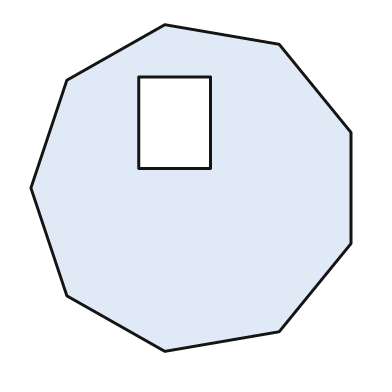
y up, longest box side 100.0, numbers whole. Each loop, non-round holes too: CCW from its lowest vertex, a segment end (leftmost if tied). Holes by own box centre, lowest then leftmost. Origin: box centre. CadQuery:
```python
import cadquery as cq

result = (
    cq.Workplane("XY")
    .moveTo(-8.0, -50.0)
    .lineTo(27.0, -44.0)
    .lineTo(49.0, -17.0)
    .lineTo(49.0, 17.0)
    .lineTo(27.0, 44.0)
    .lineTo(-8.0, 50.0)
    .lineTo(-38.0, 33.0)
    .lineTo(-49.0, 0.0)
    .lineTo(-38.0, -33.0)
    .close()
    .moveTo(-16.0, 6.0)
    .lineTo(6.0, 6.0)
    .lineTo(6.0, 34.0)
    .lineTo(-16.0, 34.0)
    .close()
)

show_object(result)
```